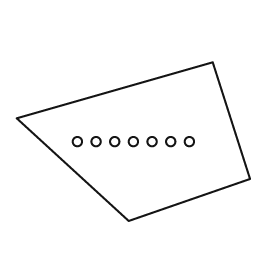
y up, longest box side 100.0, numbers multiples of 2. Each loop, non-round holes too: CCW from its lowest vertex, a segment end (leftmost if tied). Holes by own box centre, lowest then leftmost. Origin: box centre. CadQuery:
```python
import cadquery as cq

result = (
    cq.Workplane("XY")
    .moveTo(-2.0, -34.0)
    .lineTo(50.0, -16.0)
    .lineTo(34.0, 34.0)
    .lineTo(-50.0, 10.0)
    .close()
    .moveTo(-24.0, 0.0)
    .circle(2.0)
    .moveTo(-16.0, 0.0)
    .circle(2.0)
    .moveTo(-8.0, 0.0)
    .circle(2.0)
    .moveTo(0.0, 0.0)
    .circle(2.0)
    .moveTo(8.0, 0.0)
    .circle(2.0)
    .moveTo(16.0, 0.0)
    .circle(2.0)
    .moveTo(24.0, 0.0)
    .circle(2.0)
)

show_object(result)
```